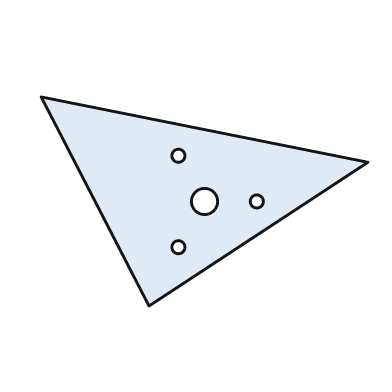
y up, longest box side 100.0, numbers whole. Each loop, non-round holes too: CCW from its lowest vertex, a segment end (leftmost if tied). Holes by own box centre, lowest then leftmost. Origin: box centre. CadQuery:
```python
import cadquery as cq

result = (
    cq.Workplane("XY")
    .moveTo(-17.0, -32.0)
    .lineTo(50.0, 12.0)
    .lineTo(-50.0, 32.0)
    .close()
    .moveTo(-8.0, -14.0)
    .circle(2.0)
    .moveTo(0.0, 0.0)
    .circle(4.0)
    .moveTo(16.0, 0.0)
    .circle(2.0)
    .moveTo(-8.0, 14.0)
    .circle(2.0)
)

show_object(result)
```